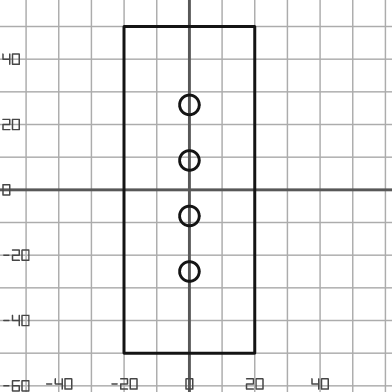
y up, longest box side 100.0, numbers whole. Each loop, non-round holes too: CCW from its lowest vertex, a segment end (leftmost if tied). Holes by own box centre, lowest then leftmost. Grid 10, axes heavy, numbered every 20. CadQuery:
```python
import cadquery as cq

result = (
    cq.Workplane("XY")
    .moveTo(-20.0, -50.0)
    .lineTo(20.0, -50.0)
    .lineTo(20.0, 50.0)
    .lineTo(-20.0, 50.0)
    .close()
    .moveTo(0.0, -25.0)
    .circle(3.0)
    .moveTo(0.0, -8.0)
    .circle(3.0)
    .moveTo(0.0, 9.0)
    .circle(3.0)
    .moveTo(0.0, 26.0)
    .circle(3.0)
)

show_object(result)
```